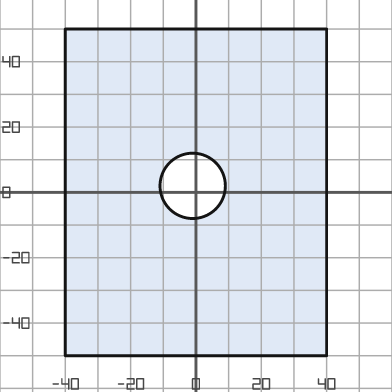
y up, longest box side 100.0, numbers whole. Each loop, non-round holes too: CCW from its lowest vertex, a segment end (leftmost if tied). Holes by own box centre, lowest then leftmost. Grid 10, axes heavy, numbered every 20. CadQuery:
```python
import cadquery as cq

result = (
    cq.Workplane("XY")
    .moveTo(-40.0, -50.0)
    .lineTo(40.0, -50.0)
    .lineTo(40.0, 50.0)
    .lineTo(-40.0, 50.0)
    .close()
    .moveTo(-1.0, 2.0)
    .circle(10.0)
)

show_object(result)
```